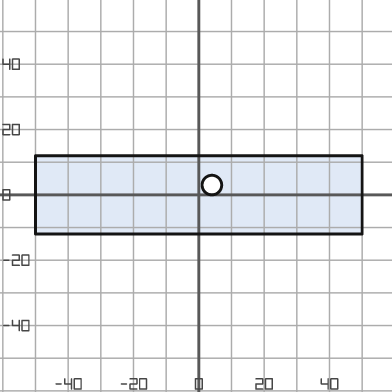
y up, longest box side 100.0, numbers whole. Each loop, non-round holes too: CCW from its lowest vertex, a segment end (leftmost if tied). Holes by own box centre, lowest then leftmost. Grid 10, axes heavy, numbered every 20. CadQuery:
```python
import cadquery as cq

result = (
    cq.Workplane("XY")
    .moveTo(-50.0, -12.0)
    .lineTo(50.0, -12.0)
    .lineTo(50.0, 12.0)
    .lineTo(-50.0, 12.0)
    .close()
    .moveTo(4.0, 3.0)
    .circle(3.0)
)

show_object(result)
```